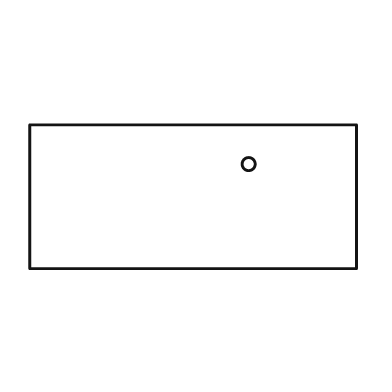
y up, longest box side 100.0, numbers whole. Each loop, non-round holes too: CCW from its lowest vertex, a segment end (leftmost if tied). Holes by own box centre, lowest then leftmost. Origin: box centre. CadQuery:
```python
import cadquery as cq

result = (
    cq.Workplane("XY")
    .moveTo(-50.0, -22.0)
    .lineTo(50.0, -22.0)
    .lineTo(50.0, 22.0)
    .lineTo(-50.0, 22.0)
    .close()
    .moveTo(17.0, 10.0)
    .circle(2.0)
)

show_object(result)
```